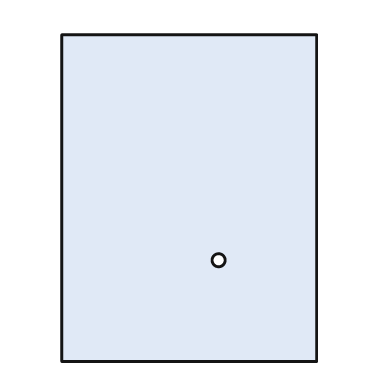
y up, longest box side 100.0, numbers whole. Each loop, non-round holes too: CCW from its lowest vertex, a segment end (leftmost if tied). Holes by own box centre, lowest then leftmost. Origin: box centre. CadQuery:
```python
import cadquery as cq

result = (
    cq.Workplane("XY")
    .moveTo(-39.0, -50.0)
    .lineTo(39.0, -50.0)
    .lineTo(39.0, 50.0)
    .lineTo(-39.0, 50.0)
    .close()
    .moveTo(9.0, -19.0)
    .circle(2.0)
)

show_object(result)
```